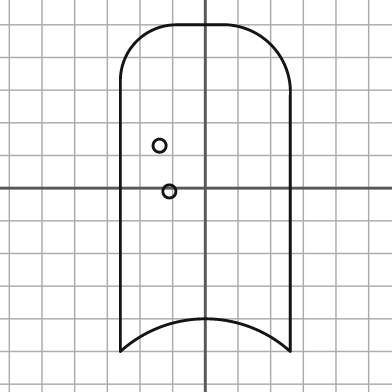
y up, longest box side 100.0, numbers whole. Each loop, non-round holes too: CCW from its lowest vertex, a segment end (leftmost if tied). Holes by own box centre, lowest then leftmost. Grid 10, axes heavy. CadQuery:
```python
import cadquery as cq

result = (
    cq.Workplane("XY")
    .moveTo(-26.0, -50.0)
    .threePointArc((0.0, -40.0), (26.0, -50.0))
    .lineTo(26.0, 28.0)
    .threePointArc((20.0, 44.0), (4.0, 50.0))
    .lineTo(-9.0, 50.0)
    .threePointArc((-21.0, 45.0), (-26.0, 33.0))
    .close()
    .moveTo(-11.0, -1.0)
    .circle(2.0)
    .moveTo(-14.0, 13.0)
    .circle(2.0)
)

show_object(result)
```